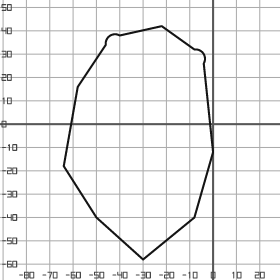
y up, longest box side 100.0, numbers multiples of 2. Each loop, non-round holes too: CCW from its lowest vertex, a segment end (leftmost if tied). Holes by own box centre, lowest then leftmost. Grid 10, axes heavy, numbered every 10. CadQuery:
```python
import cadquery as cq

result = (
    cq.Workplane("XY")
    .moveTo(-30.0, -58.0)
    .lineTo(-8.0, -40.0)
    .lineTo(0.0, -12.0)
    .lineTo(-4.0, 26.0)
    .threePointArc((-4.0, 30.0), (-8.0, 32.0))
    .lineTo(-22.0, 42.0)
    .lineTo(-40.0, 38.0)
    .threePointArc((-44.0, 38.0), (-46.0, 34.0))
    .lineTo(-58.0, 16.0)
    .lineTo(-64.0, -18.0)
    .lineTo(-50.0, -40.0)
    .close()
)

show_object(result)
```